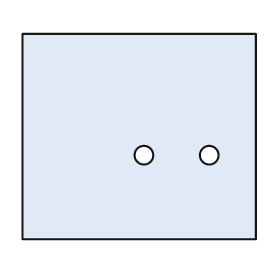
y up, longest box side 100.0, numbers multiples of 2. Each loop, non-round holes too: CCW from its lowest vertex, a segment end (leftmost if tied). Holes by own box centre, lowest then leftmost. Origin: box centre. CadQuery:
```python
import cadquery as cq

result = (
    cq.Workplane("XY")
    .moveTo(-50.0, -44.0)
    .lineTo(50.0, -44.0)
    .lineTo(50.0, 44.0)
    .lineTo(-50.0, 44.0)
    .close()
    .moveTo(2.0, -8.0)
    .circle(4.0)
    .moveTo(30.0, -8.0)
    .circle(4.0)
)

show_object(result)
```